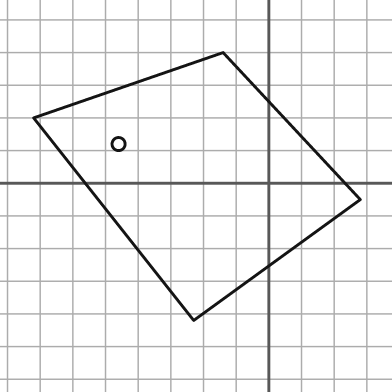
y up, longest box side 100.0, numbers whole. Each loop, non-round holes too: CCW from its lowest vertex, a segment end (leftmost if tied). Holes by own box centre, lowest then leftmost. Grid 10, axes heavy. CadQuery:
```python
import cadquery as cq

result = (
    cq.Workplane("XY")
    .moveTo(-23.0, -42.0)
    .lineTo(28.0, -5.0)
    .lineTo(-14.0, 40.0)
    .lineTo(-72.0, 20.0)
    .close()
    .moveTo(-46.0, 12.0)
    .circle(2.0)
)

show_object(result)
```